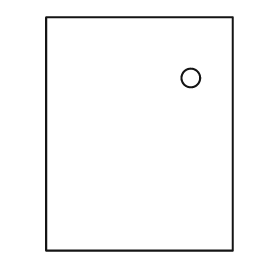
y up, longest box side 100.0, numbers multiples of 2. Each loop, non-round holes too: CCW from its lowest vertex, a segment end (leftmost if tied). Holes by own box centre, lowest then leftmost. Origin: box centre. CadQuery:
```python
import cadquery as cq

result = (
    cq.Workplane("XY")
    .moveTo(-40.0, -50.0)
    .lineTo(40.0, -50.0)
    .lineTo(40.0, 50.0)
    .lineTo(-40.0, 50.0)
    .close()
    .moveTo(22.0, 24.0)
    .circle(4.0)
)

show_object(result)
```